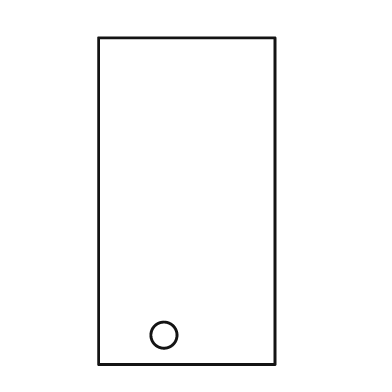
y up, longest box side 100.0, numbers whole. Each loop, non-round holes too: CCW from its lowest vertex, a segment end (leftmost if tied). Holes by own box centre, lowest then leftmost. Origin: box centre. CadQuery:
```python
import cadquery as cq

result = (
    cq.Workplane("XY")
    .moveTo(-27.0, -50.0)
    .lineTo(27.0, -50.0)
    .lineTo(27.0, 50.0)
    .lineTo(-27.0, 50.0)
    .close()
    .moveTo(-7.0, -41.0)
    .circle(4.0)
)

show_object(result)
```